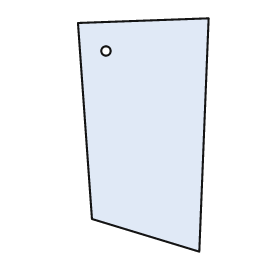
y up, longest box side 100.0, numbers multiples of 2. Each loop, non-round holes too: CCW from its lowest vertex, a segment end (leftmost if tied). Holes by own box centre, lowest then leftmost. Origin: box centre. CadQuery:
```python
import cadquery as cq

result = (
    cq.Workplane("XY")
    .moveTo(24.0, -50.0)
    .lineTo(28.0, 50.0)
    .lineTo(-28.0, 48.0)
    .lineTo(-22.0, -36.0)
    .close()
    .moveTo(-16.0, 36.0)
    .circle(2.0)
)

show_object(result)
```